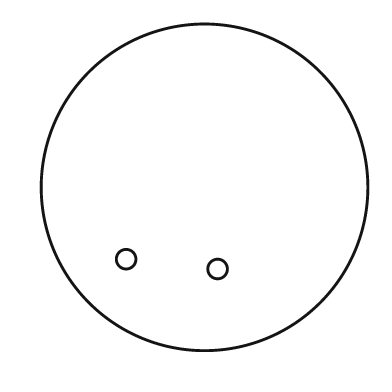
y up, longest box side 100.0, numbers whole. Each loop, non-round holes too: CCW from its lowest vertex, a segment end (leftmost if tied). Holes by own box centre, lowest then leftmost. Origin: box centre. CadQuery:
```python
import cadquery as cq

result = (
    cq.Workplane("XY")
    .moveTo(0.0, 0.0)
    .circle(50.0)
    .moveTo(4.0, -25.0)
    .circle(3.0)
    .moveTo(-24.0, -22.0)
    .circle(3.0)
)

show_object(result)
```